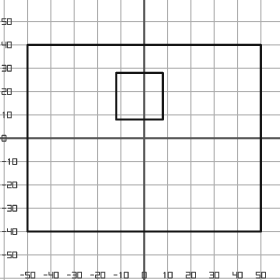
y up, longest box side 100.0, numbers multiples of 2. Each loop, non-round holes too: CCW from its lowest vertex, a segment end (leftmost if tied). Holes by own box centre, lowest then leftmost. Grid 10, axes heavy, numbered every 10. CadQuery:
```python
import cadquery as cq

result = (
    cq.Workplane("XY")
    .moveTo(-50.0, -40.0)
    .lineTo(50.0, -40.0)
    .lineTo(50.0, 40.0)
    .lineTo(-50.0, 40.0)
    .close()
    .moveTo(-12.0, 8.0)
    .lineTo(8.0, 8.0)
    .lineTo(8.0, 28.0)
    .lineTo(-12.0, 28.0)
    .close()
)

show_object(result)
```